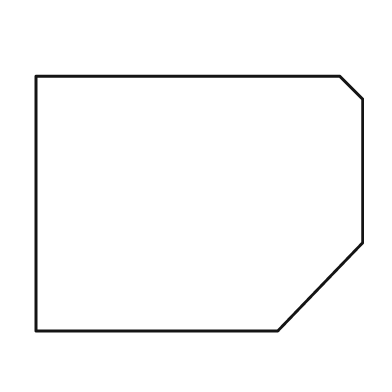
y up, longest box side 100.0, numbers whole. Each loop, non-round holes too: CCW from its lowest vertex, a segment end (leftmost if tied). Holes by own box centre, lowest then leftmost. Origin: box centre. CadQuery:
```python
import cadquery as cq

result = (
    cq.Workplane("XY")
    .moveTo(-50.0, -39.0)
    .lineTo(24.0, -39.0)
    .lineTo(50.0, -12.0)
    .lineTo(50.0, 32.0)
    .lineTo(43.0, 39.0)
    .lineTo(-50.0, 39.0)
    .close()
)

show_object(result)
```